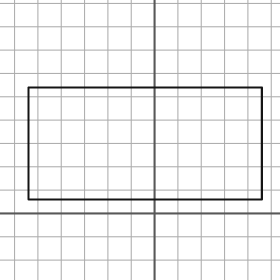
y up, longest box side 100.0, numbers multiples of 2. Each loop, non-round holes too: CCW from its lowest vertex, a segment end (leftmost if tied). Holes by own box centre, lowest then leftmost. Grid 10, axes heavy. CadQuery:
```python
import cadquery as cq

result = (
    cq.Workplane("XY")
    .moveTo(-54.0, 6.0)
    .lineTo(46.0, 6.0)
    .lineTo(46.0, 54.0)
    .lineTo(-54.0, 54.0)
    .close()
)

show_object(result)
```